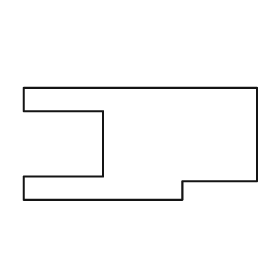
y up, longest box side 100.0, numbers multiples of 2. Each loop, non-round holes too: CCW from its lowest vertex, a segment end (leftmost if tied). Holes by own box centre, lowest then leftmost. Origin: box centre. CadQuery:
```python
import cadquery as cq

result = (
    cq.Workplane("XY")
    .moveTo(-50.0, -24.0)
    .lineTo(18.0, -24.0)
    .lineTo(18.0, -16.0)
    .lineTo(50.0, -16.0)
    .lineTo(50.0, 24.0)
    .lineTo(-50.0, 24.0)
    .lineTo(-50.0, 14.0)
    .lineTo(-16.0, 14.0)
    .lineTo(-16.0, -14.0)
    .lineTo(-50.0, -14.0)
    .close()
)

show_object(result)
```